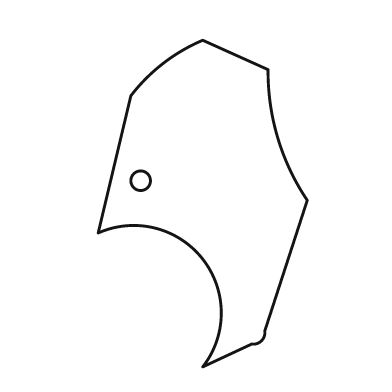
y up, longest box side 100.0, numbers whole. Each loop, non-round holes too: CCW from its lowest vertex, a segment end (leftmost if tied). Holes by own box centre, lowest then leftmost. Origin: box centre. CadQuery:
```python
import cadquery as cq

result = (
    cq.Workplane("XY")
    .moveTo(0.0, -50.0)
    .lineTo(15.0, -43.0)
    .threePointArc((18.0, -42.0), (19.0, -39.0))
    .lineTo(32.0, 1.0)
    .threePointArc((23.0, 20.0), (20.0, 41.0))
    .lineTo(0.0, 50.0)
    .threePointArc((-12.0, 43.0), (-22.0, 33.0))
    .lineTo(-32.0, -9.0)
    .threePointArc((0.0, -17.0), (0.0, -50.0))
    .close()
    .moveTo(-19.0, 7.0)
    .circle(3.0)
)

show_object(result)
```